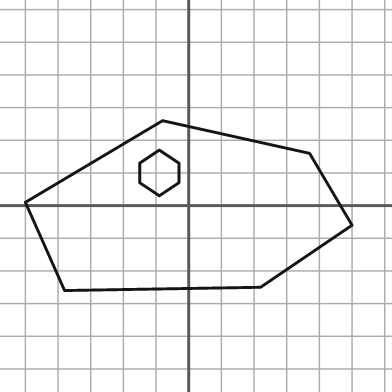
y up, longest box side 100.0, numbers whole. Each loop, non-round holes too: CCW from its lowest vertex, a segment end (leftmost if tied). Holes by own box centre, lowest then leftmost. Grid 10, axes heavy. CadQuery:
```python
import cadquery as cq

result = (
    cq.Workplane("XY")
    .moveTo(-38.0, -26.0)
    .lineTo(22.0, -25.0)
    .lineTo(50.0, -6.0)
    .lineTo(37.0, 16.0)
    .lineTo(-8.0, 26.0)
    .lineTo(-50.0, 1.0)
    .close()
    .moveTo(-9.0, 3.0)
    .lineTo(-3.0, 7.0)
    .lineTo(-3.0, 13.0)
    .lineTo(-9.0, 17.0)
    .lineTo(-15.0, 13.0)
    .lineTo(-15.0, 7.0)
    .close()
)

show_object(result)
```